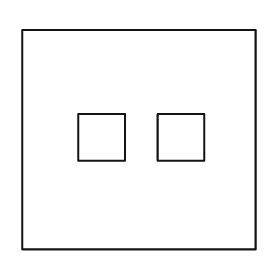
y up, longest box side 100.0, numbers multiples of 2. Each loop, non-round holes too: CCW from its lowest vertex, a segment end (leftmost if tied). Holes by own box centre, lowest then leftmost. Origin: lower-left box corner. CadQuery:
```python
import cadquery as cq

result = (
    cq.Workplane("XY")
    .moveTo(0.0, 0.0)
    .lineTo(100.0, 0.0)
    .lineTo(100.0, 94.0)
    .lineTo(0.0, 94.0)
    .close()
    .moveTo(24.0, 38.0)
    .lineTo(44.0, 38.0)
    .lineTo(44.0, 58.0)
    .lineTo(24.0, 58.0)
    .close()
    .moveTo(58.0, 38.0)
    .lineTo(78.0, 38.0)
    .lineTo(78.0, 58.0)
    .lineTo(58.0, 58.0)
    .close()
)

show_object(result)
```